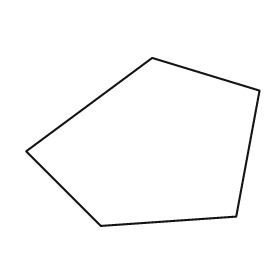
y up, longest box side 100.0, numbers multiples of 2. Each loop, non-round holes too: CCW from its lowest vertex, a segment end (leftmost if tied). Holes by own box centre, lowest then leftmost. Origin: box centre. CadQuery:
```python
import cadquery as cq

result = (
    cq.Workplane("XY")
    .moveTo(-18.0, -36.0)
    .lineTo(40.0, -32.0)
    .lineTo(50.0, 22.0)
    .lineTo(4.0, 36.0)
    .lineTo(-50.0, -4.0)
    .close()
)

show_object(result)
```